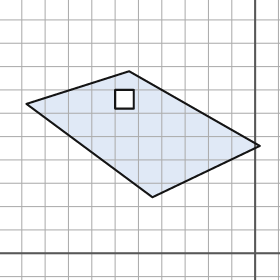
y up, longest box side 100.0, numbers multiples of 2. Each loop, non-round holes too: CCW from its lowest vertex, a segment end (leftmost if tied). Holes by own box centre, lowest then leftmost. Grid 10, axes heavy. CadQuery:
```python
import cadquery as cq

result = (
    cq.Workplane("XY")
    .moveTo(-44.0, 24.0)
    .lineTo(2.0, 46.0)
    .lineTo(-54.0, 78.0)
    .lineTo(-98.0, 64.0)
    .close()
    .moveTo(-60.0, 62.0)
    .lineTo(-52.0, 62.0)
    .lineTo(-52.0, 70.0)
    .lineTo(-60.0, 70.0)
    .close()
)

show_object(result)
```